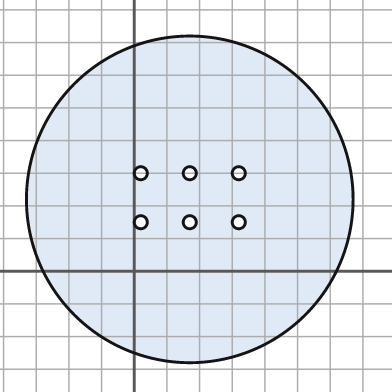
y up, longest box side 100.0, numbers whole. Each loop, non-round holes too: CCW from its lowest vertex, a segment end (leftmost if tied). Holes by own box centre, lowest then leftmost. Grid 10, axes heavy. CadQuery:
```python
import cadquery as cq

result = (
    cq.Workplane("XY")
    .moveTo(17.0, 22.0)
    .circle(50.0)
    .moveTo(2.0, 15.0)
    .circle(2.0)
    .moveTo(17.0, 15.0)
    .circle(2.0)
    .moveTo(32.0, 15.0)
    .circle(2.0)
    .moveTo(2.0, 30.0)
    .circle(2.0)
    .moveTo(17.0, 30.0)
    .circle(2.0)
    .moveTo(32.0, 30.0)
    .circle(2.0)
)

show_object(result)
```